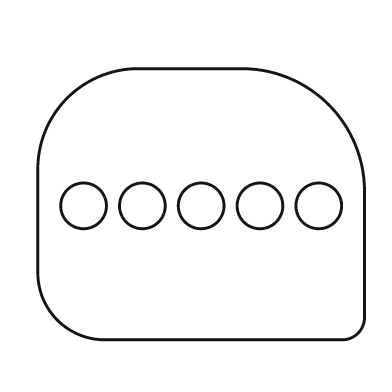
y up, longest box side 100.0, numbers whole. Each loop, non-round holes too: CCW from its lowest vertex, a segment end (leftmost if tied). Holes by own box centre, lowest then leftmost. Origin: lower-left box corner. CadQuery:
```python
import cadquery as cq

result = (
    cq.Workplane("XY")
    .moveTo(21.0, 0.0)
    .lineTo(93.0, 0.0)
    .threePointArc((98.0, 2.0), (100.0, 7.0))
    .lineTo(100.0, 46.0)
    .threePointArc((89.0, 72.0), (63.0, 83.0))
    .lineTo(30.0, 83.0)
    .threePointArc((9.0, 74.0), (0.0, 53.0))
    .lineTo(0.0, 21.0)
    .threePointArc((6.0, 6.0), (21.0, 0.0))
    .close()
    .moveTo(14.0, 41.0)
    .circle(7.0)
    .moveTo(32.0, 41.0)
    .circle(7.0)
    .moveTo(50.0, 41.0)
    .circle(7.0)
    .moveTo(68.0, 41.0)
    .circle(7.0)
    .moveTo(86.0, 41.0)
    .circle(7.0)
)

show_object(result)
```